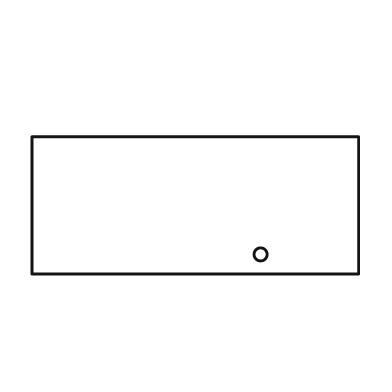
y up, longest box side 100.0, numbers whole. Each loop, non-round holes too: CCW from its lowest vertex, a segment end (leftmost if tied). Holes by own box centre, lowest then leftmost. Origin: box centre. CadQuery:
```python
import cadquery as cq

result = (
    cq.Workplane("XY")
    .moveTo(-50.0, -21.0)
    .lineTo(50.0, -21.0)
    .lineTo(50.0, 21.0)
    .lineTo(-50.0, 21.0)
    .close()
    .moveTo(20.0, -15.0)
    .circle(2.0)
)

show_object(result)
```